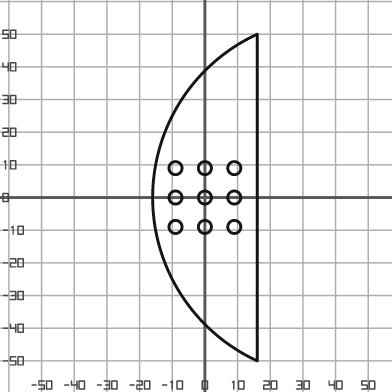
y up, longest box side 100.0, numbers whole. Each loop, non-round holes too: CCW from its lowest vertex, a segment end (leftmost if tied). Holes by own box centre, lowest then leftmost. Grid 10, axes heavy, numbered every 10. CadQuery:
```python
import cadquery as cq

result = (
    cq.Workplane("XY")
    .moveTo(16.0, -50.0)
    .lineTo(16.0, 50.0)
    .threePointArc((-16.0, 0.0), (16.0, -50.0))
    .close()
    .moveTo(-9.0, -9.0)
    .circle(2.0)
    .moveTo(0.0, -9.0)
    .circle(2.0)
    .moveTo(9.0, -9.0)
    .circle(2.0)
    .moveTo(-9.0, 0.0)
    .circle(2.0)
    .moveTo(0.0, 0.0)
    .circle(2.0)
    .moveTo(9.0, 0.0)
    .circle(2.0)
    .moveTo(-9.0, 9.0)
    .circle(2.0)
    .moveTo(0.0, 9.0)
    .circle(2.0)
    .moveTo(9.0, 9.0)
    .circle(2.0)
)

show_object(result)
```